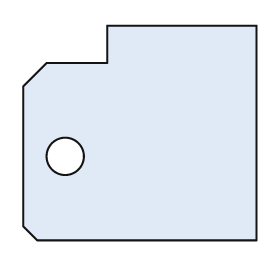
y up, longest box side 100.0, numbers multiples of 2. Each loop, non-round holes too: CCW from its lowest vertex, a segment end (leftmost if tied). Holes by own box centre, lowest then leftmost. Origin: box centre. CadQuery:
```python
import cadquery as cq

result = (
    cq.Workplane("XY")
    .moveTo(-44.0, -46.0)
    .lineTo(50.0, -46.0)
    .lineTo(50.0, 46.0)
    .lineTo(-14.0, 46.0)
    .lineTo(-14.0, 30.0)
    .lineTo(-40.0, 30.0)
    .lineTo(-50.0, 20.0)
    .lineTo(-50.0, -40.0)
    .close()
    .moveTo(-32.0, -10.0)
    .circle(8.0)
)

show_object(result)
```